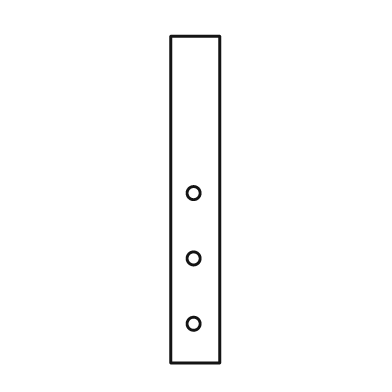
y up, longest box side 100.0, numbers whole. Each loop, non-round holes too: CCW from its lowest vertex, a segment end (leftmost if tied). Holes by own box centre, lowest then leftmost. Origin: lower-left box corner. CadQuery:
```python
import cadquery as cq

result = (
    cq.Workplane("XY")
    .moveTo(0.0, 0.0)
    .lineTo(15.0, 0.0)
    .lineTo(15.0, 100.0)
    .lineTo(0.0, 100.0)
    .close()
    .moveTo(7.0, 12.0)
    .circle(2.0)
    .moveTo(7.0, 32.0)
    .circle(2.0)
    .moveTo(7.0, 52.0)
    .circle(2.0)
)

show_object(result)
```